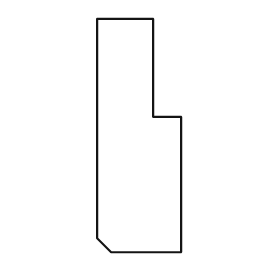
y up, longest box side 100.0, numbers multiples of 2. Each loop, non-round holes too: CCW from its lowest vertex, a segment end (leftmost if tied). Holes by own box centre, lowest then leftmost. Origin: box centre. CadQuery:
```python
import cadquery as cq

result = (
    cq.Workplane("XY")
    .moveTo(-12.0, -50.0)
    .lineTo(18.0, -50.0)
    .lineTo(18.0, 8.0)
    .lineTo(6.0, 8.0)
    .lineTo(6.0, 50.0)
    .lineTo(-18.0, 50.0)
    .lineTo(-18.0, -44.0)
    .close()
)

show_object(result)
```